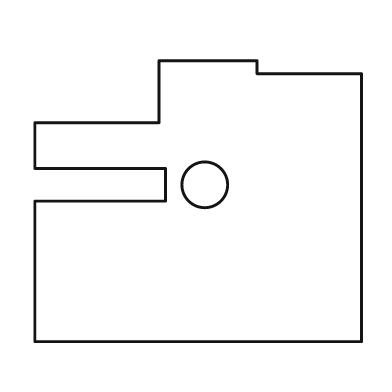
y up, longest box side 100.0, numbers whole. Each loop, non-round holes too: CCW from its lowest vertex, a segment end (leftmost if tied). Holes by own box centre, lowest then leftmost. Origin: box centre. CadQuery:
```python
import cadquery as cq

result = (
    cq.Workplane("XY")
    .moveTo(-50.0, -43.0)
    .lineTo(50.0, -43.0)
    .lineTo(50.0, 39.0)
    .lineTo(18.0, 39.0)
    .lineTo(18.0, 43.0)
    .lineTo(-12.0, 43.0)
    .lineTo(-12.0, 24.0)
    .lineTo(-50.0, 24.0)
    .lineTo(-50.0, 10.0)
    .lineTo(-10.0, 10.0)
    .lineTo(-10.0, 0.0)
    .lineTo(-50.0, 0.0)
    .close()
    .moveTo(2.0, 5.0)
    .circle(7.0)
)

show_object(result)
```